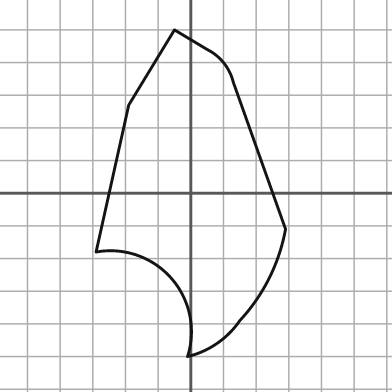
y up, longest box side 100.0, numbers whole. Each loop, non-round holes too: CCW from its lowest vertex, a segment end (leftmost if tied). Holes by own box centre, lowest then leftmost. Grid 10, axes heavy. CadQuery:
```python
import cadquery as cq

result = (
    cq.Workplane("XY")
    .moveTo(-1.0, -50.0)
    .threePointArc((8.0, -46.0), (15.0, -39.0))
    .threePointArc((24.0, -26.0), (29.0, -11.0))
    .lineTo(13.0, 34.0)
    .threePointArc((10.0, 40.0), (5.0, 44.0))
    .lineTo(-5.0, 50.0)
    .lineTo(-19.0, 27.0)
    .lineTo(-29.0, -18.0)
    .threePointArc((-6.0, -26.0), (-1.0, -50.0))
    .close()
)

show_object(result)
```